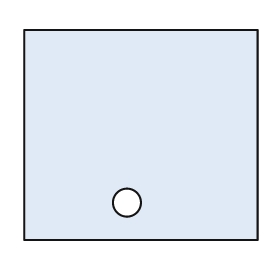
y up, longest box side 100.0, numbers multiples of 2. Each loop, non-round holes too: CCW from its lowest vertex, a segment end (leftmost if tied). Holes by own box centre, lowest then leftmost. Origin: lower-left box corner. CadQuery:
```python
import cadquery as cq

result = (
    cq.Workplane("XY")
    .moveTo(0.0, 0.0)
    .lineTo(100.0, 0.0)
    .lineTo(100.0, 90.0)
    .lineTo(0.0, 90.0)
    .close()
    .moveTo(44.0, 16.0)
    .circle(6.0)
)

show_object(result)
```